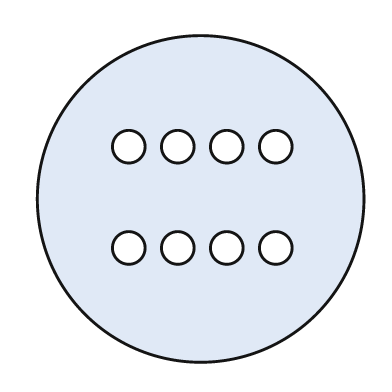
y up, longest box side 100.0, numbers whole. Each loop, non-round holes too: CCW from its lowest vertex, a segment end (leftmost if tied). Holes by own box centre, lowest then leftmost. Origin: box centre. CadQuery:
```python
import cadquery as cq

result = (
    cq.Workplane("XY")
    .moveTo(0.0, 0.0)
    .circle(50.0)
    .moveTo(-22.0, -15.0)
    .circle(5.0)
    .moveTo(-7.0, -15.0)
    .circle(5.0)
    .moveTo(8.0, -15.0)
    .circle(5.0)
    .moveTo(23.0, -15.0)
    .circle(5.0)
    .moveTo(-22.0, 16.0)
    .circle(5.0)
    .moveTo(-7.0, 16.0)
    .circle(5.0)
    .moveTo(8.0, 16.0)
    .circle(5.0)
    .moveTo(23.0, 16.0)
    .circle(5.0)
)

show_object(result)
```